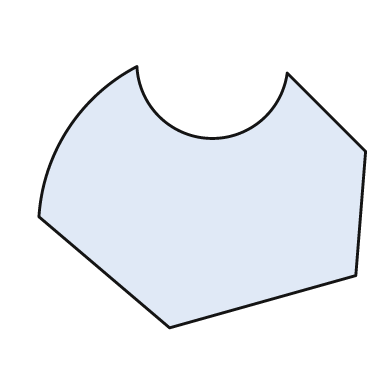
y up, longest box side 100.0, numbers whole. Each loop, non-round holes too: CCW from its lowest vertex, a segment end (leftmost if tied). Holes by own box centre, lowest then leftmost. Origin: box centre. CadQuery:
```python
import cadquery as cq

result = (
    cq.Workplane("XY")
    .moveTo(-10.0, -40.0)
    .lineTo(47.0, -24.0)
    .lineTo(50.0, 14.0)
    .lineTo(26.0, 38.0)
    .threePointArc((2.0, 18.0), (-20.0, 40.0))
    .threePointArc((-41.0, 21.0), (-50.0, -6.0))
    .close()
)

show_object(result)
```